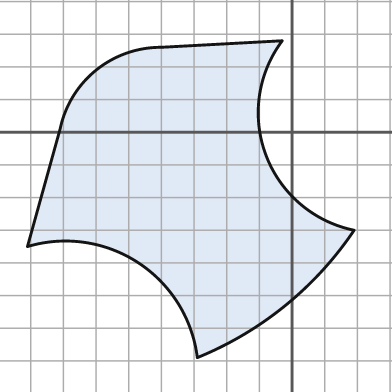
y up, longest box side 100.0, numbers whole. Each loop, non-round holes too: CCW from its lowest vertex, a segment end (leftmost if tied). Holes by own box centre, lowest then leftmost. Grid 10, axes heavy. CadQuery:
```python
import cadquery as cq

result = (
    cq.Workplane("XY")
    .moveTo(-29.0, -69.0)
    .threePointArc((-2.0, -53.0), (19.0, -30.0))
    .threePointArc((-8.0, -7.0), (-3.0, 28.0))
    .lineTo(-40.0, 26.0)
    .threePointArc((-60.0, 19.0), (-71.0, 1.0))
    .lineTo(-81.0, -35.0)
    .threePointArc((-47.0, -40.0), (-29.0, -69.0))
    .close()
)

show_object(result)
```